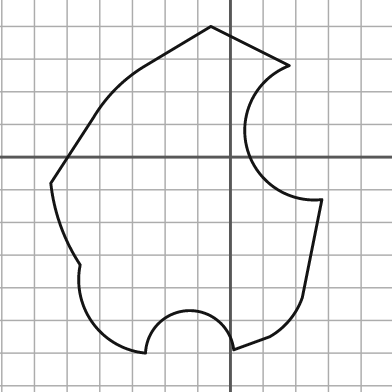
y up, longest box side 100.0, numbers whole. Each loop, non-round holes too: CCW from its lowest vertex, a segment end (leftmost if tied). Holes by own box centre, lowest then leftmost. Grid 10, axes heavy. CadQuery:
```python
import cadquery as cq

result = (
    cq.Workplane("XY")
    .moveTo(-26.0, -60.0)
    .threePointArc((-13.0, -47.0), (1.0, -59.0))
    .lineTo(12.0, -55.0)
    .threePointArc((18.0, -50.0), (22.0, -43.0))
    .lineTo(28.0, -13.0)
    .threePointArc((5.0, 3.0), (18.0, 28.0))
    .lineTo(-6.0, 40.0)
    .lineTo(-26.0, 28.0)
    .threePointArc((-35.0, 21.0), (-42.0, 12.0))
    .lineTo(-55.0, -8.0)
    .threePointArc((-52.0, -21.0), (-46.0, -33.0))
    .threePointArc((-42.0, -51.0), (-26.0, -60.0))
    .close()
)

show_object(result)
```